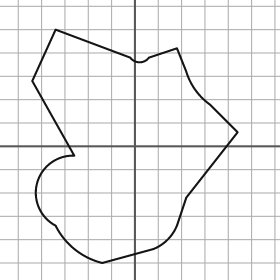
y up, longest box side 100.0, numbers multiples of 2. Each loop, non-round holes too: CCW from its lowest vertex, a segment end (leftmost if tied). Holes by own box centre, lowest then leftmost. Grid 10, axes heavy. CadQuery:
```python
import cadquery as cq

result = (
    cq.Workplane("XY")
    .moveTo(-14.0, -50.0)
    .lineTo(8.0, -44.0)
    .threePointArc((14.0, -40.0), (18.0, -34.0))
    .lineTo(22.0, -22.0)
    .lineTo(44.0, 6.0)
    .lineTo(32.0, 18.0)
    .threePointArc((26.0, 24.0), (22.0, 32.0))
    .lineTo(18.0, 42.0)
    .lineTo(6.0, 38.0)
    .threePointArc((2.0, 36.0), (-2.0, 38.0))
    .lineTo(-34.0, 50.0)
    .lineTo(-44.0, 28.0)
    .lineTo(-26.0, -4.0)
    .threePointArc((-42.0, -16.0), (-34.0, -34.0))
    .threePointArc((-26.0, -44.0), (-14.0, -50.0))
    .close()
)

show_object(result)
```